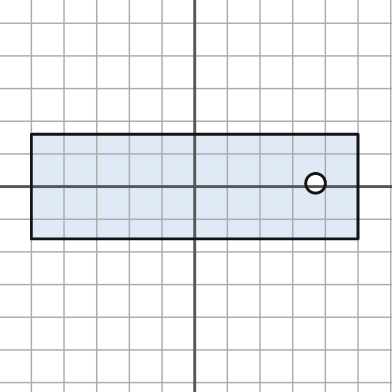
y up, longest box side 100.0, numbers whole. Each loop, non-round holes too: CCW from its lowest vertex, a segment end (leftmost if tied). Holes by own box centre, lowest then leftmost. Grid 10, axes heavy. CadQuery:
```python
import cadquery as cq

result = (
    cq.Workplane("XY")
    .moveTo(-50.0, -16.0)
    .lineTo(50.0, -16.0)
    .lineTo(50.0, 16.0)
    .lineTo(-50.0, 16.0)
    .close()
    .moveTo(37.0, 1.0)
    .circle(3.0)
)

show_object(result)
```